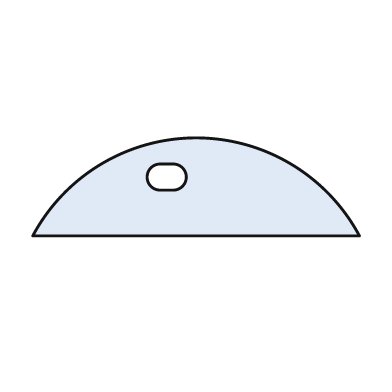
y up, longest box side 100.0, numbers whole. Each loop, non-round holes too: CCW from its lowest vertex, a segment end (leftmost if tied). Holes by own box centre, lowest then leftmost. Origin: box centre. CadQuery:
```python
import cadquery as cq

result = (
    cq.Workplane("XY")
    .moveTo(-50.0, -15.0)
    .lineTo(50.0, -15.0)
    .threePointArc((0.0, 15.0), (-50.0, -15.0))
    .close()
    .moveTo(-11.0, -1.0)
    .lineTo(-7.0, -1.0)
    .threePointArc((-3.0, 3.0), (-7.0, 7.0))
    .lineTo(-11.0, 7.0)
    .threePointArc((-15.0, 3.0), (-11.0, -1.0))
    .close()
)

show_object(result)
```